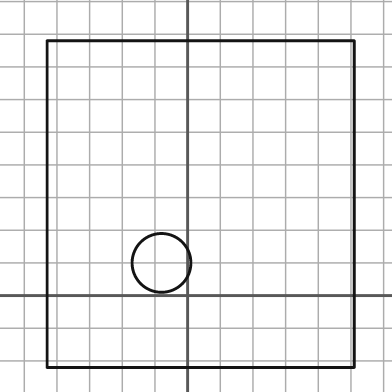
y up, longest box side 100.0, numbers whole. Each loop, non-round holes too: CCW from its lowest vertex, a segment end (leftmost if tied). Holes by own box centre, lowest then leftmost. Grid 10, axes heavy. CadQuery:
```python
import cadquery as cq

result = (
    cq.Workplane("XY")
    .moveTo(-43.0, -22.0)
    .lineTo(51.0, -22.0)
    .lineTo(51.0, 78.0)
    .lineTo(-43.0, 78.0)
    .close()
    .moveTo(-8.0, 10.0)
    .circle(9.0)
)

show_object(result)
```